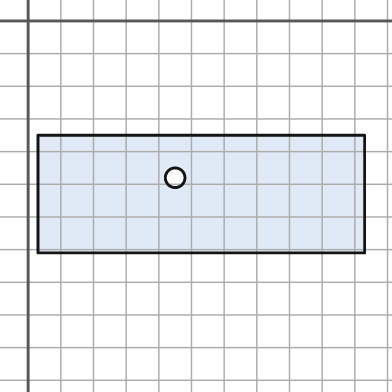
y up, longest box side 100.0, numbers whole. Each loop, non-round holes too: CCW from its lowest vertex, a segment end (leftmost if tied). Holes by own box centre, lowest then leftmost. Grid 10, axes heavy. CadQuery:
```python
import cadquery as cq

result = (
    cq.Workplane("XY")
    .moveTo(3.0, -71.0)
    .lineTo(103.0, -71.0)
    .lineTo(103.0, -35.0)
    .lineTo(3.0, -35.0)
    .close()
    .moveTo(45.0, -48.0)
    .circle(3.0)
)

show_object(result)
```